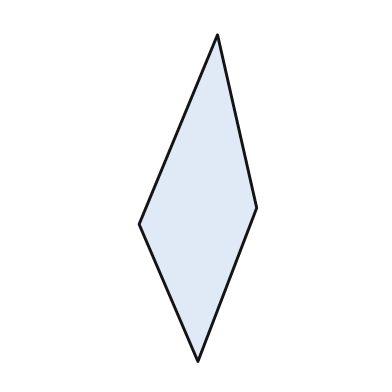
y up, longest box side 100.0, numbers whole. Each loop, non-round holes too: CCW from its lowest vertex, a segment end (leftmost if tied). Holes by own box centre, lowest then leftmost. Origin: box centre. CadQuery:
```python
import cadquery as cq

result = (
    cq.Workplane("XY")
    .moveTo(0.0, -50.0)
    .lineTo(18.0, -3.0)
    .lineTo(6.0, 50.0)
    .lineTo(-18.0, -8.0)
    .close()
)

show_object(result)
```